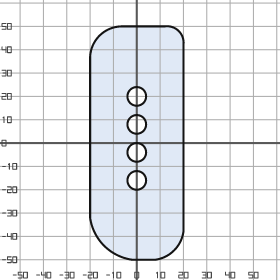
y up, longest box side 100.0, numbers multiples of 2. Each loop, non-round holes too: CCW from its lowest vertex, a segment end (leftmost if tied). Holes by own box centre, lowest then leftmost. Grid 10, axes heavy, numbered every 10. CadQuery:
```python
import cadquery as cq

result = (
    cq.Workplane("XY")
    .moveTo(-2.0, -50.0)
    .lineTo(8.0, -50.0)
    .threePointArc((16.0, -46.0), (20.0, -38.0))
    .lineTo(20.0, 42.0)
    .threePointArc((18.0, 48.0), (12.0, 50.0))
    .lineTo(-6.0, 50.0)
    .threePointArc((-16.0, 46.0), (-20.0, 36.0))
    .lineTo(-20.0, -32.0)
    .threePointArc((-14.0, -44.0), (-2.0, -50.0))
    .close()
    .moveTo(0.0, -16.0)
    .circle(4.0)
    .moveTo(0.0, -4.0)
    .circle(4.0)
    .moveTo(0.0, 8.0)
    .circle(4.0)
    .moveTo(0.0, 20.0)
    .circle(4.0)
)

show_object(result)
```